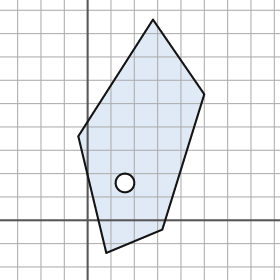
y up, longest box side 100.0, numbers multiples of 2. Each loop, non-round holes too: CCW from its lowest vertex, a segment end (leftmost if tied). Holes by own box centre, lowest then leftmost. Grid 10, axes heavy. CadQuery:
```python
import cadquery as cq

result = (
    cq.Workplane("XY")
    .moveTo(8.0, -14.0)
    .lineTo(32.0, -4.0)
    .lineTo(50.0, 54.0)
    .lineTo(28.0, 86.0)
    .lineTo(-4.0, 36.0)
    .close()
    .moveTo(16.0, 16.0)
    .circle(4.0)
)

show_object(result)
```